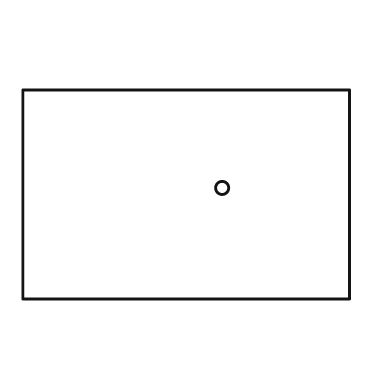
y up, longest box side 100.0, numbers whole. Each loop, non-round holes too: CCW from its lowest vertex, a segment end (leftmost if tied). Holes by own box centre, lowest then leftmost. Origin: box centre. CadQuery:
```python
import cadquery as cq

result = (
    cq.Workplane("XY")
    .moveTo(-50.0, -32.0)
    .lineTo(50.0, -32.0)
    .lineTo(50.0, 32.0)
    .lineTo(-50.0, 32.0)
    .close()
    .moveTo(11.0, 2.0)
    .circle(2.0)
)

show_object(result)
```